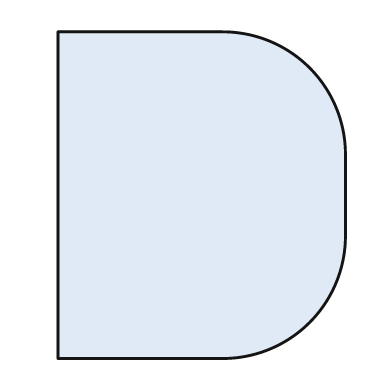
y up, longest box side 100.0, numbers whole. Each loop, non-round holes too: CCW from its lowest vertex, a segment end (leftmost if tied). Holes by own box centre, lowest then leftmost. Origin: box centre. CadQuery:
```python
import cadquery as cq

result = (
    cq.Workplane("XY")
    .moveTo(-44.0, -50.0)
    .lineTo(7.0, -50.0)
    .threePointArc((33.0, -39.0), (44.0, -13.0))
    .lineTo(44.0, 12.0)
    .threePointArc((33.0, 39.0), (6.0, 50.0))
    .lineTo(-44.0, 50.0)
    .close()
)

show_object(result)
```